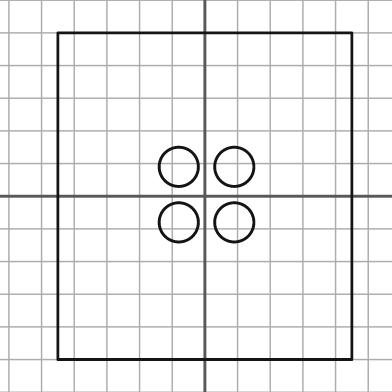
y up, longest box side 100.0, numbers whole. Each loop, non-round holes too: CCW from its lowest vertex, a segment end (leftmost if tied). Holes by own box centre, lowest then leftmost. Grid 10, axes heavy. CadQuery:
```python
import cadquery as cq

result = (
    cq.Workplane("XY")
    .moveTo(-45.0, -50.0)
    .lineTo(45.0, -50.0)
    .lineTo(45.0, 50.0)
    .lineTo(-45.0, 50.0)
    .close()
    .moveTo(-8.0, -8.0)
    .circle(6.0)
    .moveTo(9.0, -8.0)
    .circle(6.0)
    .moveTo(-8.0, 9.0)
    .circle(6.0)
    .moveTo(9.0, 9.0)
    .circle(6.0)
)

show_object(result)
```